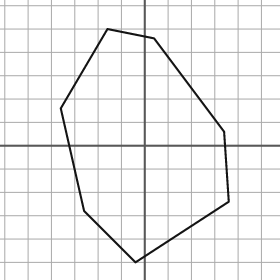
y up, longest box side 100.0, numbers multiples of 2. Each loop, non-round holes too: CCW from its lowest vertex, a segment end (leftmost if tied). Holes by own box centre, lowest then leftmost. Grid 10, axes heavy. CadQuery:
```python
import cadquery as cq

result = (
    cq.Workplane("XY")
    .moveTo(-4.0, -50.0)
    .lineTo(36.0, -24.0)
    .lineTo(34.0, 6.0)
    .lineTo(4.0, 46.0)
    .lineTo(-16.0, 50.0)
    .lineTo(-36.0, 16.0)
    .lineTo(-26.0, -28.0)
    .close()
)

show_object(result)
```